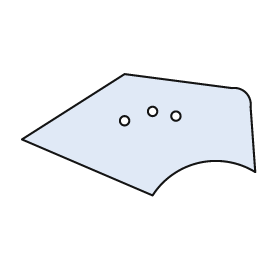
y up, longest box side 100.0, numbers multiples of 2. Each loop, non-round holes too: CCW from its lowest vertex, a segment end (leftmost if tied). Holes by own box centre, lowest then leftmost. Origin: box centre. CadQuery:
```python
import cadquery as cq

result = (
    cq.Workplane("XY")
    .moveTo(6.0, -26.0)
    .threePointArc((26.0, -12.0), (50.0, -16.0))
    .lineTo(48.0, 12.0)
    .threePointArc((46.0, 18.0), (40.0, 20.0))
    .lineTo(-6.0, 26.0)
    .lineTo(-50.0, -2.0)
    .close()
    .moveTo(-6.0, 6.0)
    .circle(2.0)
    .moveTo(16.0, 8.0)
    .circle(2.0)
    .moveTo(6.0, 10.0)
    .circle(2.0)
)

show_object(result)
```